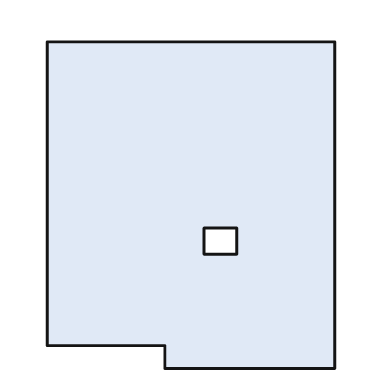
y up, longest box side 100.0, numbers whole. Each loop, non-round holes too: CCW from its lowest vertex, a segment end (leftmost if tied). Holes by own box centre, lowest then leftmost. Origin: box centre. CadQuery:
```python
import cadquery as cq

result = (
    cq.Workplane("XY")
    .moveTo(-8.0, -50.0)
    .lineTo(44.0, -50.0)
    .lineTo(44.0, 50.0)
    .lineTo(-44.0, 50.0)
    .lineTo(-44.0, -43.0)
    .lineTo(-8.0, -43.0)
    .close()
    .moveTo(4.0, -15.0)
    .lineTo(14.0, -15.0)
    .lineTo(14.0, -7.0)
    .lineTo(4.0, -7.0)
    .close()
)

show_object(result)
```